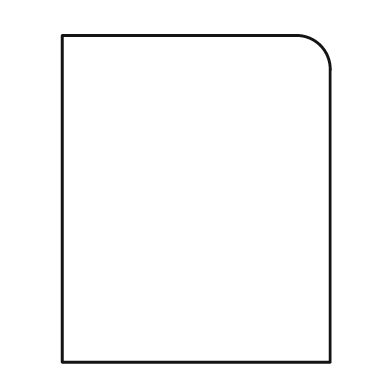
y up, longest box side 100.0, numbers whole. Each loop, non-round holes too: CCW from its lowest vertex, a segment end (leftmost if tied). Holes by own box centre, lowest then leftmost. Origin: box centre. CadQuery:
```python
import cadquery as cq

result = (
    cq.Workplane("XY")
    .moveTo(-41.0, -50.0)
    .lineTo(41.0, -50.0)
    .lineTo(41.0, 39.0)
    .threePointArc((38.0, 47.0), (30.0, 50.0))
    .lineTo(-41.0, 50.0)
    .close()
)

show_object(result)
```